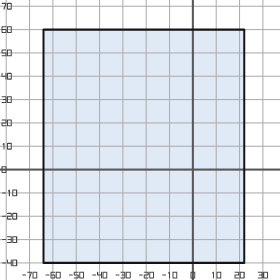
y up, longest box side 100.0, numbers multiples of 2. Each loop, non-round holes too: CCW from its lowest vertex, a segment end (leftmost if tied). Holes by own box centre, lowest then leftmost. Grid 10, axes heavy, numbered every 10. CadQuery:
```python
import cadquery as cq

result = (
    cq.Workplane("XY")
    .moveTo(-64.0, -40.0)
    .lineTo(22.0, -40.0)
    .lineTo(22.0, 60.0)
    .lineTo(-64.0, 60.0)
    .close()
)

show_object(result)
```